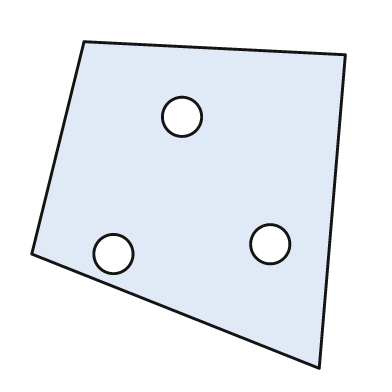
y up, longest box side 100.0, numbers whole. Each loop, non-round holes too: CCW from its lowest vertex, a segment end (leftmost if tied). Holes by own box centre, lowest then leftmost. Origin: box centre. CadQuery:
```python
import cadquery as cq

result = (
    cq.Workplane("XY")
    .moveTo(40.0, -50.0)
    .lineTo(48.0, 46.0)
    .lineTo(-32.0, 50.0)
    .lineTo(-48.0, -15.0)
    .close()
    .moveTo(-23.0, -15.0)
    .circle(6.0)
    .moveTo(25.0, -12.0)
    .circle(6.0)
    .moveTo(-2.0, 27.0)
    .circle(6.0)
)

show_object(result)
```